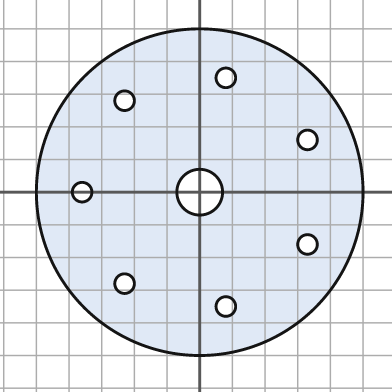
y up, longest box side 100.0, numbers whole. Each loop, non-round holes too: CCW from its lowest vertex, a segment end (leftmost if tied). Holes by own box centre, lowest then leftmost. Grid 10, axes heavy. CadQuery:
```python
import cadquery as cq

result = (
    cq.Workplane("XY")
    .moveTo(0.0, 0.0)
    .circle(50.0)
    .moveTo(8.0, -35.0)
    .circle(3.0)
    .moveTo(-23.0, -28.0)
    .circle(3.0)
    .moveTo(33.0, -16.0)
    .circle(3.0)
    .moveTo(-36.0, 0.0)
    .circle(3.0)
    .moveTo(0.0, 0.0)
    .circle(7.0)
    .moveTo(33.0, 16.0)
    .circle(3.0)
    .moveTo(-23.0, 28.0)
    .circle(3.0)
    .moveTo(8.0, 35.0)
    .circle(3.0)
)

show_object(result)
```